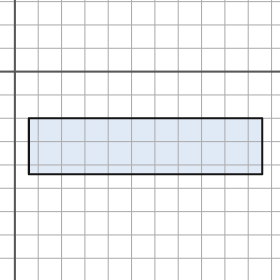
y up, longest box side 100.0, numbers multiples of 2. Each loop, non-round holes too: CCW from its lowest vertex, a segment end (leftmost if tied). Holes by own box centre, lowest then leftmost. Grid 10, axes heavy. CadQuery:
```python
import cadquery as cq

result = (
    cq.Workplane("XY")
    .moveTo(6.0, -44.0)
    .lineTo(106.0, -44.0)
    .lineTo(106.0, -20.0)
    .lineTo(6.0, -20.0)
    .close()
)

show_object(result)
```